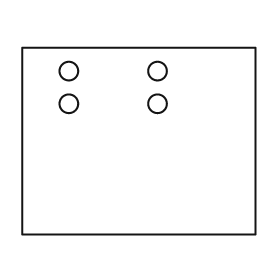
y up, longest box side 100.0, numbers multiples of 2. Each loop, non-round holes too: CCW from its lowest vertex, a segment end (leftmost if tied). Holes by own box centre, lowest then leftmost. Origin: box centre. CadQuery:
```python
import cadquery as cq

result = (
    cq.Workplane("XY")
    .moveTo(-50.0, -40.0)
    .lineTo(50.0, -40.0)
    .lineTo(50.0, 40.0)
    .lineTo(-50.0, 40.0)
    .close()
    .moveTo(-30.0, 16.0)
    .circle(4.0)
    .moveTo(8.0, 16.0)
    .circle(4.0)
    .moveTo(-30.0, 30.0)
    .circle(4.0)
    .moveTo(8.0, 30.0)
    .circle(4.0)
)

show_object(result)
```